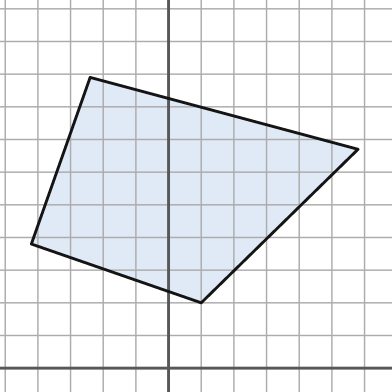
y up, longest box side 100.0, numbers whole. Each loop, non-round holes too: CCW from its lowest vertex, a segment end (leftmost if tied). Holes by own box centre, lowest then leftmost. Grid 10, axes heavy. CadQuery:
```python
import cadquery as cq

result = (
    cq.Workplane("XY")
    .moveTo(10.0, 20.0)
    .lineTo(58.0, 67.0)
    .lineTo(-24.0, 89.0)
    .lineTo(-42.0, 38.0)
    .close()
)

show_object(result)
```